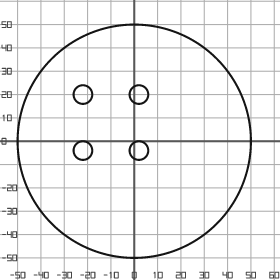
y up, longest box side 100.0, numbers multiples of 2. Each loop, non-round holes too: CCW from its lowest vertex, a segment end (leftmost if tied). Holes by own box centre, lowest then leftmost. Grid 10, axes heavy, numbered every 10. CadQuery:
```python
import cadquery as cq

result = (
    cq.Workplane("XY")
    .moveTo(0.0, 0.0)
    .circle(50.0)
    .moveTo(-22.0, -4.0)
    .circle(4.0)
    .moveTo(2.0, -4.0)
    .circle(4.0)
    .moveTo(-22.0, 20.0)
    .circle(4.0)
    .moveTo(2.0, 20.0)
    .circle(4.0)
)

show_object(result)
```